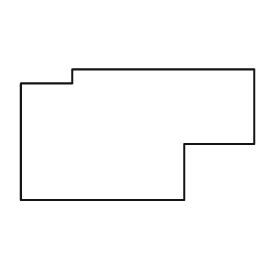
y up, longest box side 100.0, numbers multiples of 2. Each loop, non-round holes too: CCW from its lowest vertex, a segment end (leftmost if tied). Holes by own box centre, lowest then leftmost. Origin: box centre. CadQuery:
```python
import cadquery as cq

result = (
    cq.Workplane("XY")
    .moveTo(-50.0, -28.0)
    .lineTo(20.0, -28.0)
    .lineTo(20.0, -4.0)
    .lineTo(50.0, -4.0)
    .lineTo(50.0, 28.0)
    .lineTo(-28.0, 28.0)
    .lineTo(-28.0, 22.0)
    .lineTo(-50.0, 22.0)
    .close()
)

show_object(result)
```